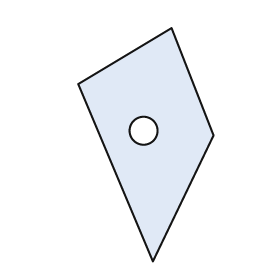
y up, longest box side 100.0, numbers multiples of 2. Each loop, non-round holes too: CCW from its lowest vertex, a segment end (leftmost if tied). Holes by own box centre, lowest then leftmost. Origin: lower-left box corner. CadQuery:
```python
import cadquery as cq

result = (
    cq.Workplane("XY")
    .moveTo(32.0, 0.0)
    .lineTo(58.0, 54.0)
    .lineTo(40.0, 100.0)
    .lineTo(0.0, 76.0)
    .close()
    .moveTo(28.0, 56.0)
    .circle(6.0)
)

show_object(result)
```